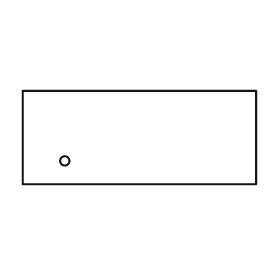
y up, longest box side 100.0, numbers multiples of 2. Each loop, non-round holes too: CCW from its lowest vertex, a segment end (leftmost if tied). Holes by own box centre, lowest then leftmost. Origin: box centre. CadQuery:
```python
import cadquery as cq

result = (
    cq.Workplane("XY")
    .moveTo(-50.0, -20.0)
    .lineTo(50.0, -20.0)
    .lineTo(50.0, 20.0)
    .lineTo(-50.0, 20.0)
    .close()
    .moveTo(-32.0, -10.0)
    .circle(2.0)
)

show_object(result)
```